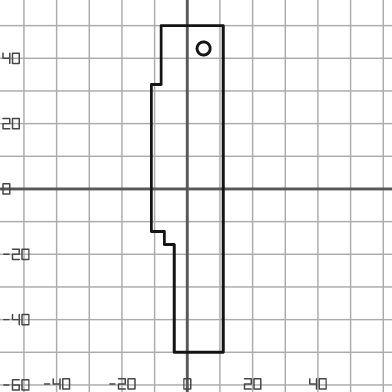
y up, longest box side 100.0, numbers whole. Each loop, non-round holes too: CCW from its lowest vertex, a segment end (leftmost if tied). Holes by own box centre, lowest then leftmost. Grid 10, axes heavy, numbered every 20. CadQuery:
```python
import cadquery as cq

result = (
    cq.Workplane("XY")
    .moveTo(-4.0, -50.0)
    .lineTo(11.0, -50.0)
    .lineTo(11.0, 50.0)
    .lineTo(-8.0, 50.0)
    .lineTo(-8.0, 32.0)
    .lineTo(-11.0, 32.0)
    .lineTo(-11.0, -13.0)
    .lineTo(-7.0, -13.0)
    .lineTo(-7.0, -17.0)
    .lineTo(-4.0, -17.0)
    .close()
    .moveTo(5.0, 43.0)
    .circle(2.0)
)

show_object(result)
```